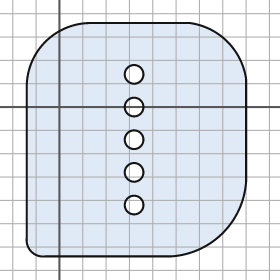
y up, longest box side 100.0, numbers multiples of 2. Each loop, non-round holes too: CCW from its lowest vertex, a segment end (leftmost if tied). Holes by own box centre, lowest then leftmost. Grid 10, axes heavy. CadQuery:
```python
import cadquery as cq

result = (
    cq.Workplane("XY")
    .moveTo(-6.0, -64.0)
    .lineTo(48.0, -64.0)
    .threePointArc((70.0, -54.0), (80.0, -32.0))
    .lineTo(80.0, 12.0)
    .threePointArc((72.0, 28.0), (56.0, 36.0))
    .lineTo(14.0, 36.0)
    .threePointArc((-6.0, 28.0), (-14.0, 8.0))
    .lineTo(-14.0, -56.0)
    .threePointArc((-12.0, -62.0), (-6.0, -64.0))
    .close()
    .moveTo(32.0, -42.0)
    .circle(4.0)
    .moveTo(32.0, -28.0)
    .circle(4.0)
    .moveTo(32.0, -14.0)
    .circle(4.0)
    .moveTo(32.0, 0.0)
    .circle(4.0)
    .moveTo(32.0, 14.0)
    .circle(4.0)
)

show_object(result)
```